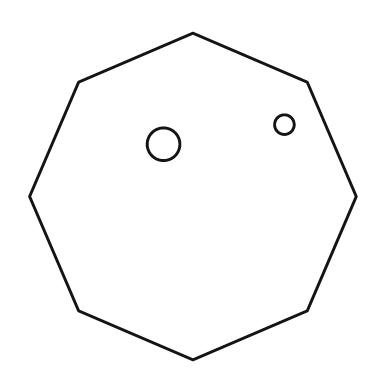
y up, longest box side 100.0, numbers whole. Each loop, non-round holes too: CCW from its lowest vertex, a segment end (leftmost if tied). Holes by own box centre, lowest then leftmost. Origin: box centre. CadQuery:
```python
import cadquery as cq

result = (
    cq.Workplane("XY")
    .moveTo(0.0, -50.0)
    .lineTo(35.0, -35.0)
    .lineTo(50.0, 0.0)
    .lineTo(35.0, 35.0)
    .lineTo(0.0, 50.0)
    .lineTo(-35.0, 35.0)
    .lineTo(-50.0, 0.0)
    .lineTo(-35.0, -35.0)
    .close()
    .moveTo(-9.0, 16.0)
    .circle(5.0)
    .moveTo(28.0, 22.0)
    .circle(3.0)
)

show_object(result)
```